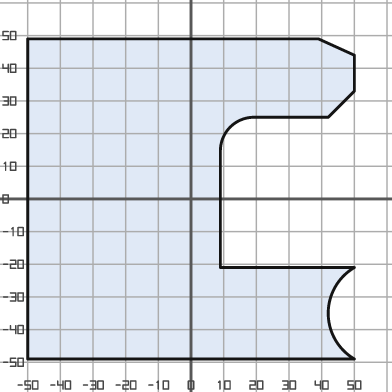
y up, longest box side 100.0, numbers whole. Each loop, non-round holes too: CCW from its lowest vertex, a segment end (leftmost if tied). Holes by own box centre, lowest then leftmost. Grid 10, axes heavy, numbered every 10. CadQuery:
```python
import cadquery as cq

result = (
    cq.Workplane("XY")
    .moveTo(-50.0, -49.0)
    .lineTo(50.0, -49.0)
    .threePointArc((42.0, -35.0), (50.0, -21.0))
    .lineTo(9.0, -21.0)
    .lineTo(9.0, 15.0)
    .threePointArc((12.0, 22.0), (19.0, 25.0))
    .lineTo(42.0, 25.0)
    .lineTo(50.0, 33.0)
    .lineTo(50.0, 44.0)
    .lineTo(39.0, 49.0)
    .lineTo(-50.0, 49.0)
    .close()
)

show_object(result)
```